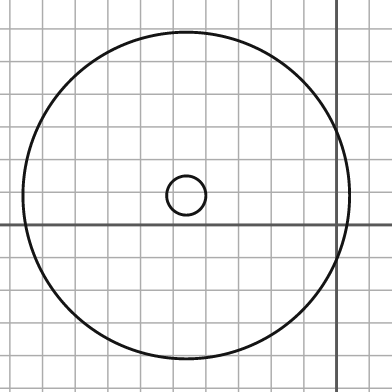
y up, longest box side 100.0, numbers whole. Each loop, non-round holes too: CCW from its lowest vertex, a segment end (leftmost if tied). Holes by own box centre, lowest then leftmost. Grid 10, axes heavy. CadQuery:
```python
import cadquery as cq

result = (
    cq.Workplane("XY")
    .moveTo(-46.0, 9.0)
    .circle(50.0)
    .moveTo(-46.0, 9.0)
    .circle(6.0)
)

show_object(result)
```